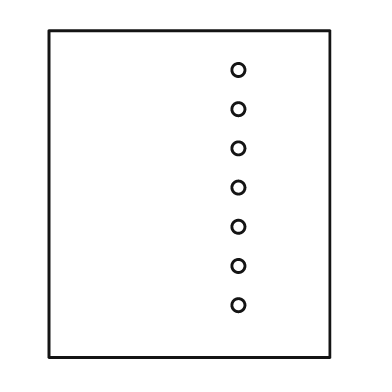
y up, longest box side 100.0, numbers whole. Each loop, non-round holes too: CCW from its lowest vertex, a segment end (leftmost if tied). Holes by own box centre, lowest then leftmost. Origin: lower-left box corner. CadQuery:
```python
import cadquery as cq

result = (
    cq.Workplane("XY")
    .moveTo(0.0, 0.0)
    .lineTo(86.0, 0.0)
    .lineTo(86.0, 100.0)
    .lineTo(0.0, 100.0)
    .close()
    .moveTo(58.0, 16.0)
    .circle(2.0)
    .moveTo(58.0, 28.0)
    .circle(2.0)
    .moveTo(58.0, 40.0)
    .circle(2.0)
    .moveTo(58.0, 52.0)
    .circle(2.0)
    .moveTo(58.0, 64.0)
    .circle(2.0)
    .moveTo(58.0, 76.0)
    .circle(2.0)
    .moveTo(58.0, 88.0)
    .circle(2.0)
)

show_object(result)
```